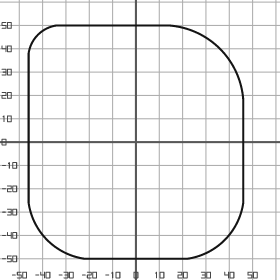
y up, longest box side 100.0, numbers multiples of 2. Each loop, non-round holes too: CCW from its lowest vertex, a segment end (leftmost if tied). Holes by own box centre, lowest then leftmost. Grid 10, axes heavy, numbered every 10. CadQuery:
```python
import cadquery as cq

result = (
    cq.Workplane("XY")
    .moveTo(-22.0, -50.0)
    .lineTo(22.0, -50.0)
    .threePointArc((38.0, -42.0), (46.0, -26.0))
    .lineTo(46.0, 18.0)
    .threePointArc((36.0, 40.0), (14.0, 50.0))
    .lineTo(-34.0, 50.0)
    .threePointArc((-42.0, 46.0), (-46.0, 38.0))
    .lineTo(-46.0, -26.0)
    .threePointArc((-38.0, -42.0), (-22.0, -50.0))
    .close()
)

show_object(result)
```